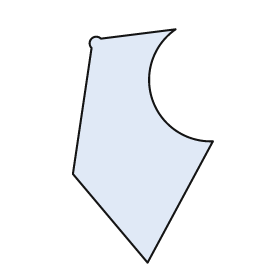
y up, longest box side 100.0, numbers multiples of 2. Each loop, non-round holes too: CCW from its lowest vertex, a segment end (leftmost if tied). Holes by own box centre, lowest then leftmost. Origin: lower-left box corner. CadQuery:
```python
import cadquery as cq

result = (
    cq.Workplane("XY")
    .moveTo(32.0, 0.0)
    .lineTo(60.0, 52.0)
    .threePointArc((34.0, 70.0), (44.0, 100.0))
    .lineTo(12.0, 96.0)
    .threePointArc((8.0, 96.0), (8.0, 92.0))
    .lineTo(0.0, 38.0)
    .close()
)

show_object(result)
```